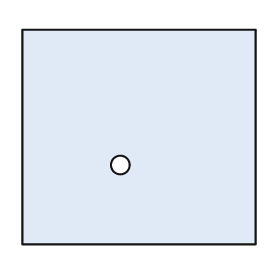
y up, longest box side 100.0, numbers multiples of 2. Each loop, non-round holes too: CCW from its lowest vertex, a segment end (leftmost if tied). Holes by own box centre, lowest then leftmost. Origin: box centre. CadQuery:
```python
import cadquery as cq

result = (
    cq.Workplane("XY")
    .moveTo(-50.0, -46.0)
    .lineTo(50.0, -46.0)
    .lineTo(50.0, 46.0)
    .lineTo(-50.0, 46.0)
    .close()
    .moveTo(-8.0, -12.0)
    .circle(4.0)
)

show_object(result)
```